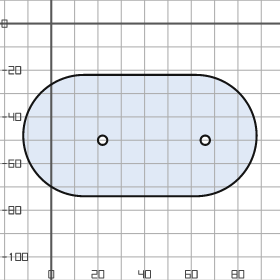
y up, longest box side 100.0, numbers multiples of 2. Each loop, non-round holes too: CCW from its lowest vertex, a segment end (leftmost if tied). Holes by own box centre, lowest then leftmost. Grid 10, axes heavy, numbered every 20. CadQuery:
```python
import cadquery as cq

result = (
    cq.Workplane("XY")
    .moveTo(14.0, -74.0)
    .lineTo(62.0, -74.0)
    .threePointArc((88.0, -48.0), (62.0, -22.0))
    .lineTo(14.0, -22.0)
    .threePointArc((-12.0, -48.0), (14.0, -74.0))
    .close()
    .moveTo(22.0, -50.0)
    .circle(2.0)
    .moveTo(66.0, -50.0)
    .circle(2.0)
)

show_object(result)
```